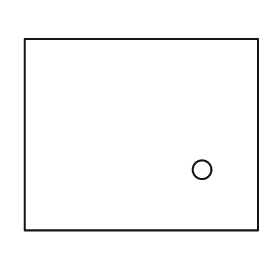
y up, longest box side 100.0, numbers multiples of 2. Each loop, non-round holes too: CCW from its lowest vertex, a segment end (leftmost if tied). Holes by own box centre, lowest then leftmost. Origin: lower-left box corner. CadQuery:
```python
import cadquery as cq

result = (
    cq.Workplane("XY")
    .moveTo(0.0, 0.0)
    .lineTo(100.0, 0.0)
    .lineTo(100.0, 82.0)
    .lineTo(0.0, 82.0)
    .close()
    .moveTo(76.0, 26.0)
    .circle(4.0)
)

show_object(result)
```